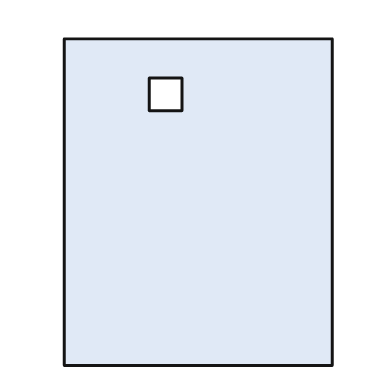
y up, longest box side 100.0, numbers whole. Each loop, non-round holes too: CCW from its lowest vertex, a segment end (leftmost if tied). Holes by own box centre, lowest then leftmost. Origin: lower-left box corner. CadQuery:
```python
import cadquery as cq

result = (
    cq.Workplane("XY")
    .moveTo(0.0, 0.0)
    .lineTo(82.0, 0.0)
    .lineTo(82.0, 100.0)
    .lineTo(0.0, 100.0)
    .close()
    .moveTo(26.0, 78.0)
    .lineTo(36.0, 78.0)
    .lineTo(36.0, 88.0)
    .lineTo(26.0, 88.0)
    .close()
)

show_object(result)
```